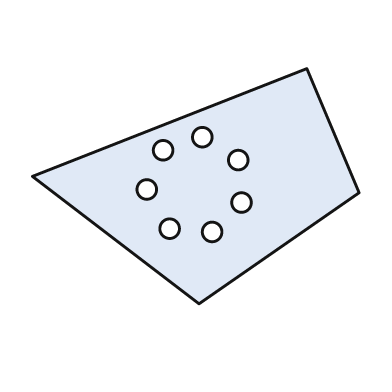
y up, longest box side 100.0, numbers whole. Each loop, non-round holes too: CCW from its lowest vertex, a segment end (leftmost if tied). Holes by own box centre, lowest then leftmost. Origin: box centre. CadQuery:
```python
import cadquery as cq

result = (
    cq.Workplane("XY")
    .moveTo(1.0, -36.0)
    .lineTo(50.0, -2.0)
    .lineTo(34.0, 36.0)
    .lineTo(-50.0, 3.0)
    .close()
    .moveTo(5.0, -14.0)
    .circle(3.0)
    .moveTo(-8.0, -13.0)
    .circle(3.0)
    .moveTo(14.0, -5.0)
    .circle(3.0)
    .moveTo(-15.0, -1.0)
    .circle(3.0)
    .moveTo(13.0, 8.0)
    .circle(3.0)
    .moveTo(-10.0, 11.0)
    .circle(3.0)
    .moveTo(2.0, 15.0)
    .circle(3.0)
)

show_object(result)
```